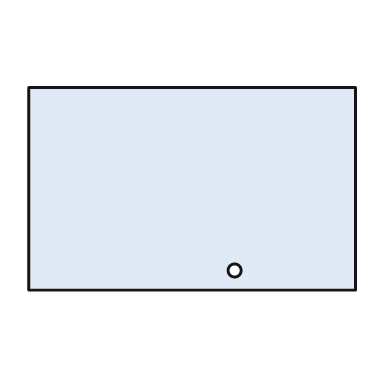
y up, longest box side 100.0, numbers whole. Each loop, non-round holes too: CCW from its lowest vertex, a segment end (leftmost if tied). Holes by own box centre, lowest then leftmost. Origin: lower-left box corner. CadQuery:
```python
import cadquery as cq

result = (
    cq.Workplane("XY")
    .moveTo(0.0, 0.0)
    .lineTo(100.0, 0.0)
    .lineTo(100.0, 62.0)
    .lineTo(0.0, 62.0)
    .close()
    .moveTo(63.0, 6.0)
    .circle(2.0)
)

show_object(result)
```